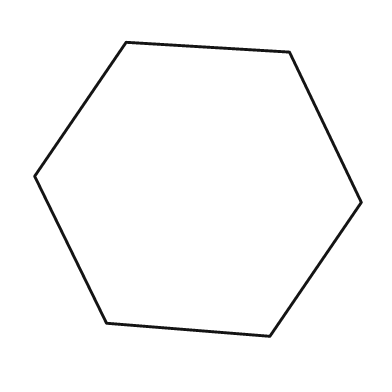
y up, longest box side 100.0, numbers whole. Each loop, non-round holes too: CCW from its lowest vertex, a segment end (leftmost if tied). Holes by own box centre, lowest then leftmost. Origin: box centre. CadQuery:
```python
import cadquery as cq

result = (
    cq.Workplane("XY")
    .moveTo(22.0, -45.0)
    .lineTo(50.0, -4.0)
    .lineTo(28.0, 42.0)
    .lineTo(-22.0, 45.0)
    .lineTo(-50.0, 4.0)
    .lineTo(-28.0, -41.0)
    .close()
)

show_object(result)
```